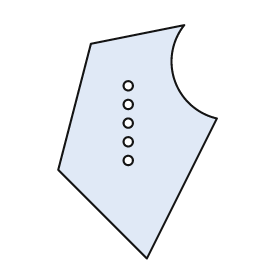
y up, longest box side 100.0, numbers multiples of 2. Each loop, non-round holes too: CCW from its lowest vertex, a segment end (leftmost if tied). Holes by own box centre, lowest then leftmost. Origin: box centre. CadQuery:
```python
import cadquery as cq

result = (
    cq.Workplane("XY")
    .moveTo(4.0, -50.0)
    .lineTo(34.0, 10.0)
    .threePointArc((16.0, 26.0), (20.0, 50.0))
    .lineTo(-20.0, 42.0)
    .lineTo(-34.0, -12.0)
    .close()
    .moveTo(-4.0, -8.0)
    .circle(2.0)
    .moveTo(-4.0, 0.0)
    .circle(2.0)
    .moveTo(-4.0, 8.0)
    .circle(2.0)
    .moveTo(-4.0, 16.0)
    .circle(2.0)
    .moveTo(-4.0, 24.0)
    .circle(2.0)
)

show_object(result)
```